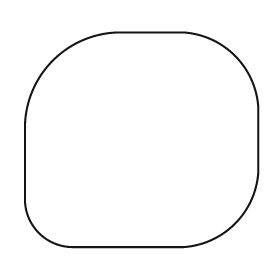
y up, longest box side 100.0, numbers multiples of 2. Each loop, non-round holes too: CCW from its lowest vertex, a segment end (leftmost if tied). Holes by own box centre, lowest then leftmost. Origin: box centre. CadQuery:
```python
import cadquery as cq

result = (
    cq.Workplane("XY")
    .moveTo(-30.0, -46.0)
    .lineTo(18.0, -46.0)
    .threePointArc((40.0, -36.0), (50.0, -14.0))
    .lineTo(50.0, 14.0)
    .threePointArc((40.0, 36.0), (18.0, 46.0))
    .lineTo(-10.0, 46.0)
    .threePointArc((-38.0, 34.0), (-50.0, 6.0))
    .lineTo(-50.0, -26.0)
    .threePointArc((-44.0, -40.0), (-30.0, -46.0))
    .close()
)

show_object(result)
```